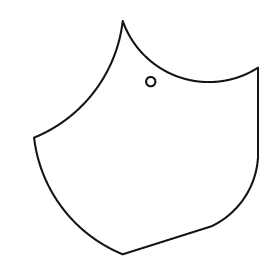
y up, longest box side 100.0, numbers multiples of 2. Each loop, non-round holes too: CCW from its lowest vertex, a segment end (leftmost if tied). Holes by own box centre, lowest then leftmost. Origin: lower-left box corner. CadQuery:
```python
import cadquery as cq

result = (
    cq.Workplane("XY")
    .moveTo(38.0, 0.0)
    .lineTo(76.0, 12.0)
    .threePointArc((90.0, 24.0), (96.0, 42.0))
    .lineTo(96.0, 80.0)
    .threePointArc((62.0, 76.0), (38.0, 100.0))
    .threePointArc((26.0, 70.0), (0.0, 50.0))
    .threePointArc((12.0, 20.0), (38.0, 0.0))
    .close()
    .moveTo(50.0, 74.0)
    .circle(2.0)
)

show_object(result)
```